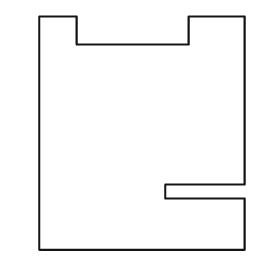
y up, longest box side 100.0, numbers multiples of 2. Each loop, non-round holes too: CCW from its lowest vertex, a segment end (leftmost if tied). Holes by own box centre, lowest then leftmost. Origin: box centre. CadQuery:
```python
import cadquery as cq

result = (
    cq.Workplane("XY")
    .moveTo(-44.0, -50.0)
    .lineTo(44.0, -50.0)
    .lineTo(44.0, -28.0)
    .lineTo(10.0, -28.0)
    .lineTo(10.0, -22.0)
    .lineTo(44.0, -22.0)
    .lineTo(44.0, 50.0)
    .lineTo(20.0, 50.0)
    .lineTo(20.0, 38.0)
    .lineTo(-28.0, 38.0)
    .lineTo(-28.0, 50.0)
    .lineTo(-44.0, 50.0)
    .close()
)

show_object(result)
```